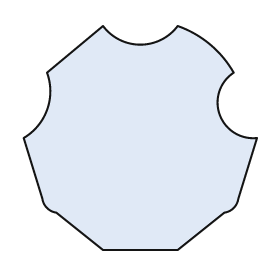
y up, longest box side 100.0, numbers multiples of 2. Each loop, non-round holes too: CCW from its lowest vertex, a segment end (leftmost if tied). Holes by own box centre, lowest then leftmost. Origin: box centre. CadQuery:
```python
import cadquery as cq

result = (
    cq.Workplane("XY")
    .moveTo(-16.0, -48.0)
    .lineTo(16.0, -48.0)
    .lineTo(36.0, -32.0)
    .threePointArc((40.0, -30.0), (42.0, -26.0))
    .lineTo(50.0, 0.0)
    .threePointArc((34.0, 10.0), (40.0, 28.0))
    .threePointArc((30.0, 40.0), (16.0, 48.0))
    .threePointArc((0.0, 40.0), (-16.0, 48.0))
    .lineTo(-40.0, 28.0)
    .threePointArc((-40.0, 12.0), (-50.0, 0.0))
    .lineTo(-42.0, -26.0)
    .threePointArc((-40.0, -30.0), (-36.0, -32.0))
    .close()
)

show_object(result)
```